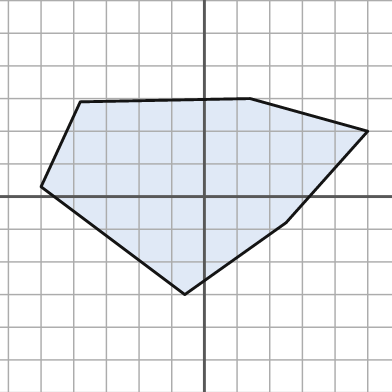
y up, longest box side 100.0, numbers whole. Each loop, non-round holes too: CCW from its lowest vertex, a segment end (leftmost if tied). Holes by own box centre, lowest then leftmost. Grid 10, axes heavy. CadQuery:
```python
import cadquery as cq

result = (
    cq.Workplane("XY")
    .moveTo(-6.0, -30.0)
    .lineTo(25.0, -8.0)
    .lineTo(50.0, 20.0)
    .lineTo(14.0, 30.0)
    .lineTo(-38.0, 29.0)
    .lineTo(-50.0, 3.0)
    .close()
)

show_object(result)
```